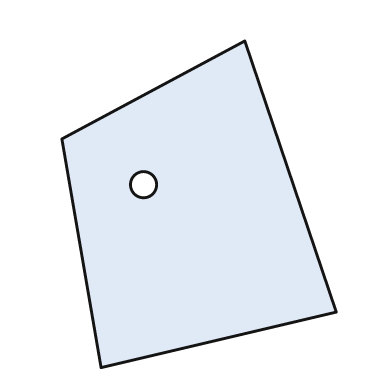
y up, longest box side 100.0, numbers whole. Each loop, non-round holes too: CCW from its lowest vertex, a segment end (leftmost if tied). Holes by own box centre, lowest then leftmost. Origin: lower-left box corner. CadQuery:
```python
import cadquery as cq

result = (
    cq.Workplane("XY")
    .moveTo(12.0, 0.0)
    .lineTo(84.0, 17.0)
    .lineTo(56.0, 100.0)
    .lineTo(0.0, 70.0)
    .close()
    .moveTo(25.0, 56.0)
    .circle(4.0)
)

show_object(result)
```